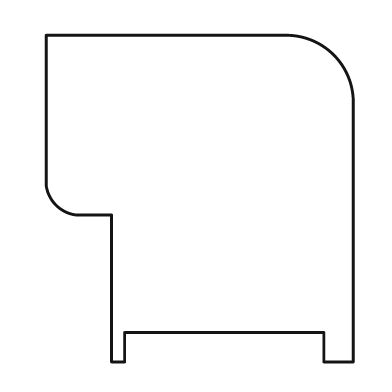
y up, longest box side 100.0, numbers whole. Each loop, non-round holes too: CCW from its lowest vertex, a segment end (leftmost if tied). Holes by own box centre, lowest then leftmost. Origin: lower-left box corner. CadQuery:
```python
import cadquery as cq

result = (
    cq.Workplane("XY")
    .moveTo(20.0, 0.0)
    .lineTo(24.0, 0.0)
    .lineTo(24.0, 9.0)
    .lineTo(85.0, 9.0)
    .lineTo(85.0, 0.0)
    .lineTo(94.0, 0.0)
    .lineTo(94.0, 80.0)
    .threePointArc((88.0, 94.0), (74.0, 100.0))
    .lineTo(0.0, 100.0)
    .lineTo(0.0, 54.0)
    .threePointArc((3.0, 48.0), (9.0, 45.0))
    .lineTo(20.0, 45.0)
    .close()
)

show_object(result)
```